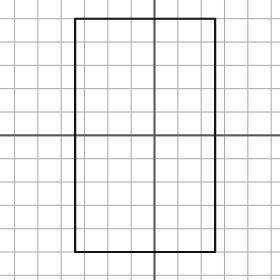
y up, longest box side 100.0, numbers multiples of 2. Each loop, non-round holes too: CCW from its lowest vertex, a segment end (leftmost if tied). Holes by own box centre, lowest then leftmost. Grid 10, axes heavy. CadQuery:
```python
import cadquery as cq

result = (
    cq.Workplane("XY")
    .moveTo(-34.0, -50.0)
    .lineTo(26.0, -50.0)
    .lineTo(26.0, 50.0)
    .lineTo(-34.0, 50.0)
    .close()
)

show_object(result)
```